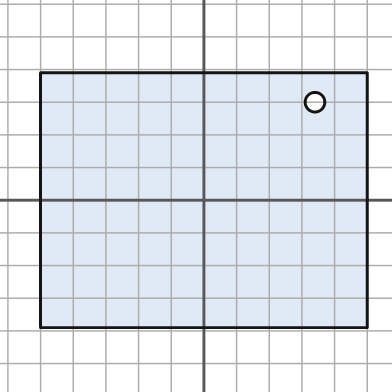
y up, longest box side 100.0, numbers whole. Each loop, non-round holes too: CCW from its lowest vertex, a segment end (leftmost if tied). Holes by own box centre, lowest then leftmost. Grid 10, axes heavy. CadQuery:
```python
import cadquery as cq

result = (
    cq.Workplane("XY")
    .moveTo(-50.0, -39.0)
    .lineTo(50.0, -39.0)
    .lineTo(50.0, 39.0)
    .lineTo(-50.0, 39.0)
    .close()
    .moveTo(34.0, 30.0)
    .circle(3.0)
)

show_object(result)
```